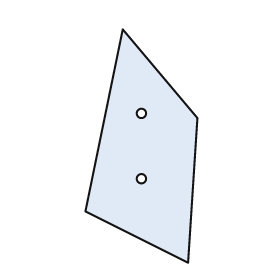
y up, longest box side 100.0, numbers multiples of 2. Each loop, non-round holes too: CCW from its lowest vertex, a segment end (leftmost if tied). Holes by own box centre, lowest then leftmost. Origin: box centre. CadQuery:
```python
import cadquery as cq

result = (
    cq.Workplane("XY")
    .moveTo(20.0, -50.0)
    .lineTo(24.0, 12.0)
    .lineTo(-8.0, 50.0)
    .lineTo(-24.0, -28.0)
    .close()
    .moveTo(0.0, -14.0)
    .circle(2.0)
    .moveTo(0.0, 14.0)
    .circle(2.0)
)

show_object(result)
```